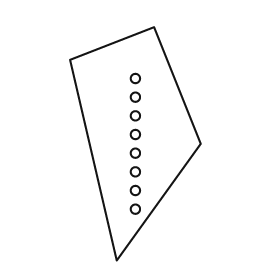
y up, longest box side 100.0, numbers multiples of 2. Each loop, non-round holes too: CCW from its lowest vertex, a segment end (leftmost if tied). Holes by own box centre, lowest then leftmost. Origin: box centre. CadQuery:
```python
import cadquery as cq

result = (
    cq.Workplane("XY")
    .moveTo(-8.0, -50.0)
    .lineTo(28.0, 0.0)
    .lineTo(8.0, 50.0)
    .lineTo(-28.0, 36.0)
    .close()
    .moveTo(0.0, -28.0)
    .circle(2.0)
    .moveTo(0.0, -20.0)
    .circle(2.0)
    .moveTo(0.0, -12.0)
    .circle(2.0)
    .moveTo(0.0, -4.0)
    .circle(2.0)
    .moveTo(0.0, 4.0)
    .circle(2.0)
    .moveTo(0.0, 12.0)
    .circle(2.0)
    .moveTo(0.0, 20.0)
    .circle(2.0)
    .moveTo(0.0, 28.0)
    .circle(2.0)
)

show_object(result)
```